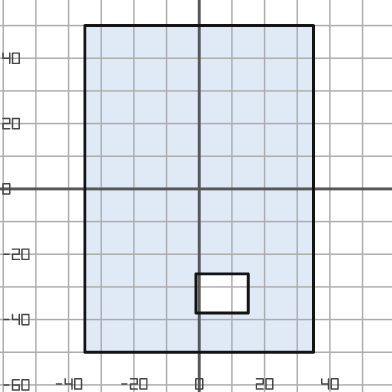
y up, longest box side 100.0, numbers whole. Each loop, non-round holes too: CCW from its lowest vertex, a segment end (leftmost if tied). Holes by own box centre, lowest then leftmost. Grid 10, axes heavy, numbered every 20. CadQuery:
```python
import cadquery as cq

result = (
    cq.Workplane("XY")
    .moveTo(-35.0, -50.0)
    .lineTo(35.0, -50.0)
    .lineTo(35.0, 50.0)
    .lineTo(-35.0, 50.0)
    .close()
    .moveTo(-1.0, -38.0)
    .lineTo(15.0, -38.0)
    .lineTo(15.0, -26.0)
    .lineTo(-1.0, -26.0)
    .close()
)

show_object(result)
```